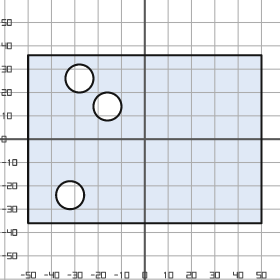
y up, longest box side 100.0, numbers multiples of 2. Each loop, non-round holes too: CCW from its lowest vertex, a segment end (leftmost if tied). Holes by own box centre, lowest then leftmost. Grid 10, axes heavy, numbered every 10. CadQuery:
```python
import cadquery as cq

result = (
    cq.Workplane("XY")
    .moveTo(-50.0, -36.0)
    .lineTo(50.0, -36.0)
    .lineTo(50.0, 36.0)
    .lineTo(-50.0, 36.0)
    .close()
    .moveTo(-32.0, -24.0)
    .circle(6.0)
    .moveTo(-16.0, 14.0)
    .circle(6.0)
    .moveTo(-28.0, 26.0)
    .circle(6.0)
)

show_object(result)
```